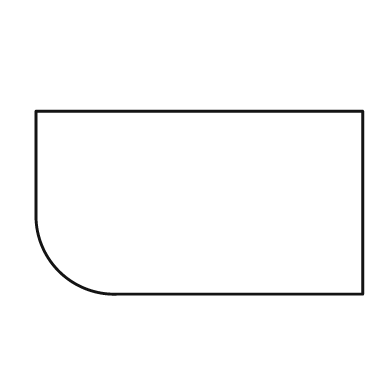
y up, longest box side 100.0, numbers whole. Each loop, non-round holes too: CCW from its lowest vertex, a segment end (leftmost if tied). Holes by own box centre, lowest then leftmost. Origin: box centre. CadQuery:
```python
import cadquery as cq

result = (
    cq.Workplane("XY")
    .moveTo(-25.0, -28.0)
    .lineTo(50.0, -28.0)
    .lineTo(50.0, 28.0)
    .lineTo(-50.0, 28.0)
    .lineTo(-50.0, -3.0)
    .threePointArc((-43.0, -21.0), (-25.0, -28.0))
    .close()
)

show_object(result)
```